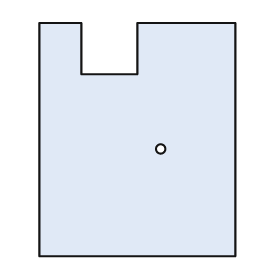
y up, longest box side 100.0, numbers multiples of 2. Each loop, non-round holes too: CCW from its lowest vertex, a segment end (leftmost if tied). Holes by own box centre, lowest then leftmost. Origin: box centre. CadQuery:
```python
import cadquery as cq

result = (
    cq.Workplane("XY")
    .moveTo(-42.0, -50.0)
    .lineTo(42.0, -50.0)
    .lineTo(42.0, 50.0)
    .lineTo(0.0, 50.0)
    .lineTo(0.0, 28.0)
    .lineTo(-24.0, 28.0)
    .lineTo(-24.0, 50.0)
    .lineTo(-42.0, 50.0)
    .close()
    .moveTo(10.0, -4.0)
    .circle(2.0)
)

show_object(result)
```